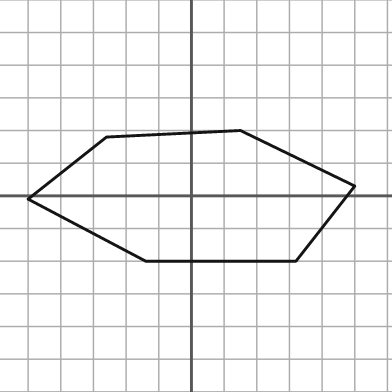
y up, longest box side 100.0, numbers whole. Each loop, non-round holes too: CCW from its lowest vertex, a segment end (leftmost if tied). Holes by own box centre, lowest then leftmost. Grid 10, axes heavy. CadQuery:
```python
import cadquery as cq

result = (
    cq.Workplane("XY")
    .moveTo(-14.0, -20.0)
    .lineTo(32.0, -20.0)
    .lineTo(50.0, 3.0)
    .lineTo(15.0, 20.0)
    .lineTo(-26.0, 18.0)
    .lineTo(-50.0, -1.0)
    .close()
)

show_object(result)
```